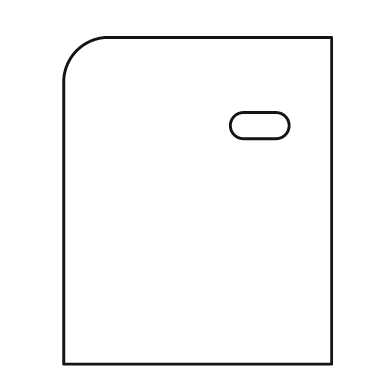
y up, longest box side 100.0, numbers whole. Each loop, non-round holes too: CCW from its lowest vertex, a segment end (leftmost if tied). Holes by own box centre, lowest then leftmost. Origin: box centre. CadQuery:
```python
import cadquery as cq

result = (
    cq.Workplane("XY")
    .moveTo(-41.0, -50.0)
    .lineTo(41.0, -50.0)
    .lineTo(41.0, 50.0)
    .lineTo(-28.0, 50.0)
    .threePointArc((-37.0, 46.0), (-41.0, 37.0))
    .close()
    .moveTo(14.0, 19.0)
    .lineTo(24.0, 19.0)
    .threePointArc((28.0, 23.0), (24.0, 27.0))
    .lineTo(14.0, 27.0)
    .threePointArc((10.0, 23.0), (14.0, 19.0))
    .close()
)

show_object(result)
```